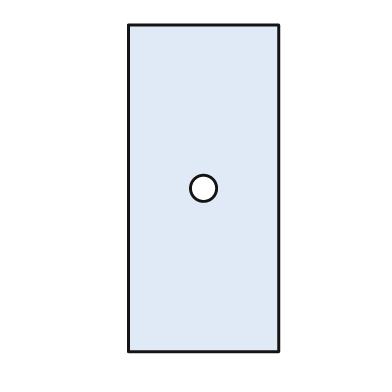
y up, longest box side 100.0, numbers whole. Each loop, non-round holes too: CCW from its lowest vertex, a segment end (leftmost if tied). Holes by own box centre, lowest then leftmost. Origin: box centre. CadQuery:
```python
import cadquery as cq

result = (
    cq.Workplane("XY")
    .moveTo(-23.0, -50.0)
    .lineTo(23.0, -50.0)
    .lineTo(23.0, 50.0)
    .lineTo(-23.0, 50.0)
    .close()
    .moveTo(0.0, 0.0)
    .circle(4.0)
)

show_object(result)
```